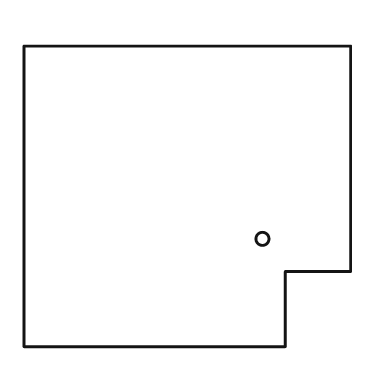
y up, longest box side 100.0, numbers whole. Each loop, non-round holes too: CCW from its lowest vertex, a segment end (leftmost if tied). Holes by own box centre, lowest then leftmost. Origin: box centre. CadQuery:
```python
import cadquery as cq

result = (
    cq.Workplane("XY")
    .moveTo(-50.0, -46.0)
    .lineTo(30.0, -46.0)
    .lineTo(30.0, -23.0)
    .lineTo(50.0, -23.0)
    .lineTo(50.0, 46.0)
    .lineTo(-50.0, 46.0)
    .close()
    .moveTo(23.0, -13.0)
    .circle(2.0)
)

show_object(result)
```